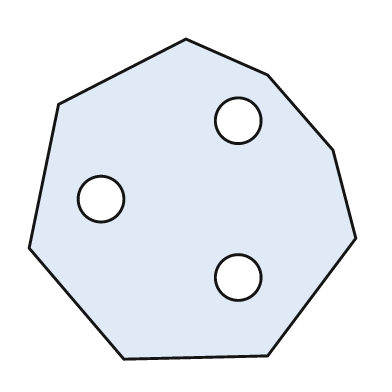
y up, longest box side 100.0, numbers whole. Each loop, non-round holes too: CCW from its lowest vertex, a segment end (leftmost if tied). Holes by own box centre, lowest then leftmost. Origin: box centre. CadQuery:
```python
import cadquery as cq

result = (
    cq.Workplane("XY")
    .moveTo(-21.0, -49.0)
    .lineTo(23.0, -48.0)
    .lineTo(50.0, -12.0)
    .lineTo(43.0, 15.0)
    .lineTo(23.0, 38.0)
    .lineTo(-2.0, 49.0)
    .lineTo(-41.0, 29.0)
    .lineTo(-50.0, -15.0)
    .close()
    .moveTo(14.0, -24.0)
    .circle(7.0)
    .moveTo(-28.0, 0.0)
    .circle(7.0)
    .moveTo(14.0, 24.0)
    .circle(7.0)
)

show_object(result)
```